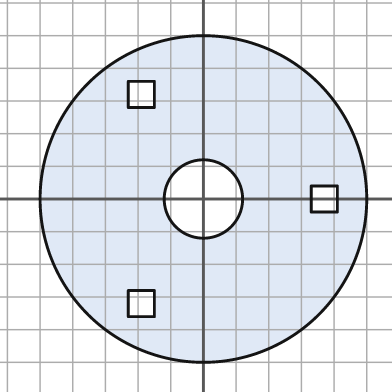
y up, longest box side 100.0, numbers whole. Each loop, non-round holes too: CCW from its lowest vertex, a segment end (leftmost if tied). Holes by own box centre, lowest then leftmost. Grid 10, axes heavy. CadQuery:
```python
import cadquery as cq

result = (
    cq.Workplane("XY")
    .moveTo(0.0, 0.0)
    .circle(50.0)
    .moveTo(-23.0, -36.0)
    .lineTo(-15.0, -36.0)
    .lineTo(-15.0, -28.0)
    .lineTo(-23.0, -28.0)
    .close()
    .moveTo(0.0, 0.0)
    .circle(12.0)
    .moveTo(33.0, -4.0)
    .lineTo(41.0, -4.0)
    .lineTo(41.0, 4.0)
    .lineTo(33.0, 4.0)
    .close()
    .moveTo(-23.0, 28.0)
    .lineTo(-15.0, 28.0)
    .lineTo(-15.0, 36.0)
    .lineTo(-23.0, 36.0)
    .close()
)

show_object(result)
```